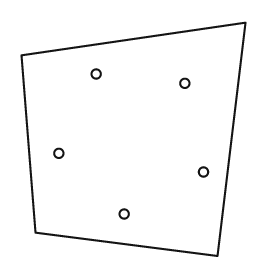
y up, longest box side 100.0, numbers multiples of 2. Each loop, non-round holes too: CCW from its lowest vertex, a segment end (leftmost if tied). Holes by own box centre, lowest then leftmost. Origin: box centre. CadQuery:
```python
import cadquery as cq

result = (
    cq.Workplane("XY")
    .moveTo(36.0, -50.0)
    .lineTo(48.0, 50.0)
    .lineTo(-48.0, 36.0)
    .lineTo(-42.0, -40.0)
    .close()
    .moveTo(-4.0, -32.0)
    .circle(2.0)
    .moveTo(30.0, -14.0)
    .circle(2.0)
    .moveTo(-32.0, -6.0)
    .circle(2.0)
    .moveTo(22.0, 24.0)
    .circle(2.0)
    .moveTo(-16.0, 28.0)
    .circle(2.0)
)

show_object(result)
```